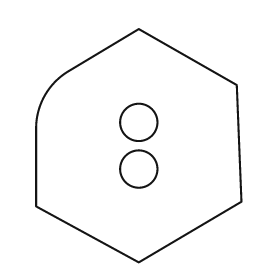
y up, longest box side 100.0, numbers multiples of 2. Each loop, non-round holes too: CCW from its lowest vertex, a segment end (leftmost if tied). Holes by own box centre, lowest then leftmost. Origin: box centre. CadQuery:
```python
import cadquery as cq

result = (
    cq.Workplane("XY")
    .moveTo(0.0, -50.0)
    .lineTo(44.0, -24.0)
    .lineTo(42.0, 26.0)
    .lineTo(0.0, 50.0)
    .lineTo(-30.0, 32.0)
    .threePointArc((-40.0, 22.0), (-44.0, 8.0))
    .lineTo(-44.0, -26.0)
    .close()
    .moveTo(0.0, -10.0)
    .circle(8.0)
    .moveTo(0.0, 10.0)
    .circle(8.0)
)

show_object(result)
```